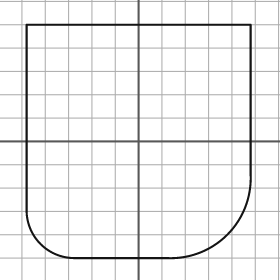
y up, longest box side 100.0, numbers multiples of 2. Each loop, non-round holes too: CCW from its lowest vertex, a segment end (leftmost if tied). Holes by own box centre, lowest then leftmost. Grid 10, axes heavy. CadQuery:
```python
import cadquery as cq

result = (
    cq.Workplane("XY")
    .moveTo(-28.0, -50.0)
    .lineTo(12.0, -50.0)
    .threePointArc((38.0, -40.0), (48.0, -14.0))
    .lineTo(48.0, 50.0)
    .lineTo(-48.0, 50.0)
    .lineTo(-48.0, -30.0)
    .threePointArc((-42.0, -44.0), (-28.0, -50.0))
    .close()
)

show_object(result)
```